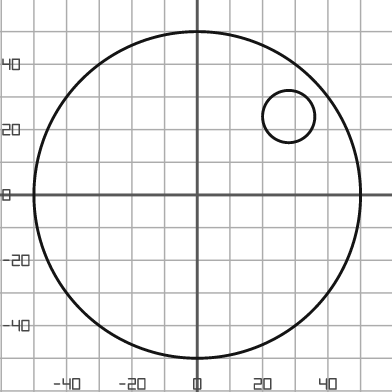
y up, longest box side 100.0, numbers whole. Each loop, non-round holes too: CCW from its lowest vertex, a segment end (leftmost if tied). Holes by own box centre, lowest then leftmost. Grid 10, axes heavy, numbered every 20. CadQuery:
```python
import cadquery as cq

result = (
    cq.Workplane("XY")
    .moveTo(0.0, 0.0)
    .circle(50.0)
    .moveTo(28.0, 24.0)
    .circle(8.0)
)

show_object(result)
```